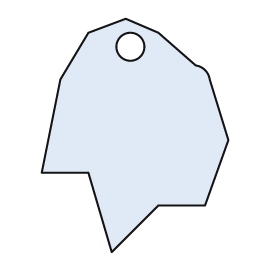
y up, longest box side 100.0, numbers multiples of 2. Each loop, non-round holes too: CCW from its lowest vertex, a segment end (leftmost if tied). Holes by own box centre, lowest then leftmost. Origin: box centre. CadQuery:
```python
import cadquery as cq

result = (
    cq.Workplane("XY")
    .moveTo(-10.0, -50.0)
    .lineTo(10.0, -30.0)
    .lineTo(30.0, -30.0)
    .lineTo(40.0, -2.0)
    .lineTo(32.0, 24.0)
    .threePointArc((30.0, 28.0), (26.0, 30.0))
    .lineTo(10.0, 44.0)
    .lineTo(-4.0, 50.0)
    .lineTo(-20.0, 44.0)
    .lineTo(-32.0, 24.0)
    .lineTo(-40.0, -16.0)
    .lineTo(-20.0, -16.0)
    .close()
    .moveTo(-2.0, 38.0)
    .circle(6.0)
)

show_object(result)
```